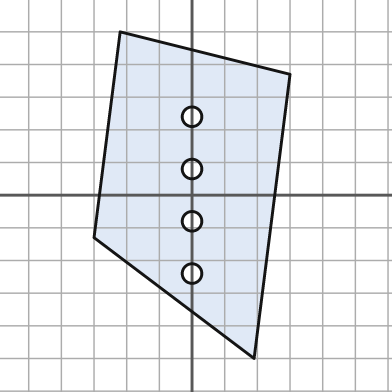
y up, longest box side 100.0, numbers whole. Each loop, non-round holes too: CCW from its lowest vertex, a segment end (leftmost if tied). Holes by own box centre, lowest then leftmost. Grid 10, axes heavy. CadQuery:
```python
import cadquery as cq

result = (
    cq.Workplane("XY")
    .moveTo(19.0, -50.0)
    .lineTo(30.0, 37.0)
    .lineTo(-22.0, 50.0)
    .lineTo(-30.0, -13.0)
    .close()
    .moveTo(0.0, -24.0)
    .circle(3.0)
    .moveTo(0.0, -8.0)
    .circle(3.0)
    .moveTo(0.0, 8.0)
    .circle(3.0)
    .moveTo(0.0, 24.0)
    .circle(3.0)
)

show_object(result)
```